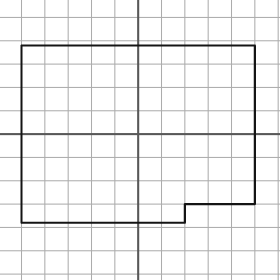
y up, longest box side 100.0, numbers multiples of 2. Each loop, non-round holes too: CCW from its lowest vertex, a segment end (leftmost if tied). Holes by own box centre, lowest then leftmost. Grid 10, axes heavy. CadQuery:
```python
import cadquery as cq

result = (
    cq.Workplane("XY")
    .moveTo(-50.0, -38.0)
    .lineTo(20.0, -38.0)
    .lineTo(20.0, -30.0)
    .lineTo(50.0, -30.0)
    .lineTo(50.0, 38.0)
    .lineTo(-50.0, 38.0)
    .close()
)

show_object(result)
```